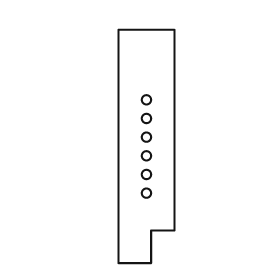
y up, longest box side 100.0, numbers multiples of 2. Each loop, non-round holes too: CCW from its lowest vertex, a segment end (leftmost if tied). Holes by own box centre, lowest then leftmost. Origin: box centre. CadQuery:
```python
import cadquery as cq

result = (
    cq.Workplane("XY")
    .moveTo(-12.0, -50.0)
    .lineTo(2.0, -50.0)
    .lineTo(2.0, -36.0)
    .lineTo(12.0, -36.0)
    .lineTo(12.0, 50.0)
    .lineTo(-12.0, 50.0)
    .close()
    .moveTo(0.0, -20.0)
    .circle(2.0)
    .moveTo(0.0, -12.0)
    .circle(2.0)
    .moveTo(0.0, -4.0)
    .circle(2.0)
    .moveTo(0.0, 4.0)
    .circle(2.0)
    .moveTo(0.0, 12.0)
    .circle(2.0)
    .moveTo(0.0, 20.0)
    .circle(2.0)
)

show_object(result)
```